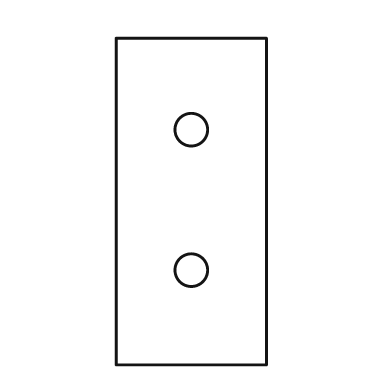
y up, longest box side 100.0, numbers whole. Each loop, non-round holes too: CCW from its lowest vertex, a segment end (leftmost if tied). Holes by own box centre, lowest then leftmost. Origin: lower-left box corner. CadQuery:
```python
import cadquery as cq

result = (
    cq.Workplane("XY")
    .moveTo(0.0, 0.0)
    .lineTo(46.0, 0.0)
    .lineTo(46.0, 100.0)
    .lineTo(0.0, 100.0)
    .close()
    .moveTo(23.0, 29.0)
    .circle(5.0)
    .moveTo(23.0, 72.0)
    .circle(5.0)
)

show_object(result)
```